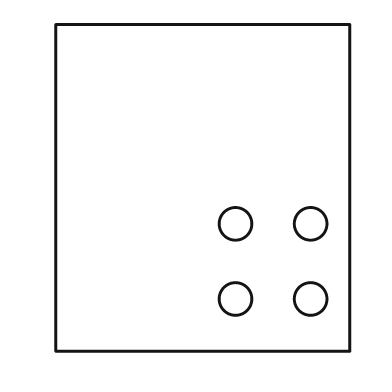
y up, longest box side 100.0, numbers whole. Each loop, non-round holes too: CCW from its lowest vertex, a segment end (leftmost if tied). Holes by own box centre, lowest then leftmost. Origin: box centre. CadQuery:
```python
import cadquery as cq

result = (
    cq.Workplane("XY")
    .moveTo(-45.0, -50.0)
    .lineTo(45.0, -50.0)
    .lineTo(45.0, 50.0)
    .lineTo(-45.0, 50.0)
    .close()
    .moveTo(10.0, -34.0)
    .circle(5.0)
    .moveTo(33.0, -34.0)
    .circle(5.0)
    .moveTo(10.0, -11.0)
    .circle(5.0)
    .moveTo(33.0, -11.0)
    .circle(5.0)
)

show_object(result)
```